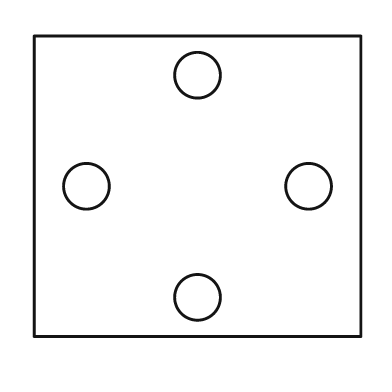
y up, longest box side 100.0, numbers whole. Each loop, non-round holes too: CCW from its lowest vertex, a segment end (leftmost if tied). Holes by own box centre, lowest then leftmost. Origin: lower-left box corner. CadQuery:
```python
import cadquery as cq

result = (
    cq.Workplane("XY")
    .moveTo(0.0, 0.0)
    .lineTo(100.0, 0.0)
    .lineTo(100.0, 92.0)
    .lineTo(0.0, 92.0)
    .close()
    .moveTo(50.0, 12.0)
    .circle(7.0)
    .moveTo(16.0, 46.0)
    .circle(7.0)
    .moveTo(84.0, 46.0)
    .circle(7.0)
    .moveTo(50.0, 80.0)
    .circle(7.0)
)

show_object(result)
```